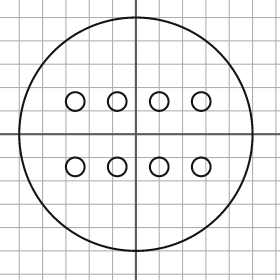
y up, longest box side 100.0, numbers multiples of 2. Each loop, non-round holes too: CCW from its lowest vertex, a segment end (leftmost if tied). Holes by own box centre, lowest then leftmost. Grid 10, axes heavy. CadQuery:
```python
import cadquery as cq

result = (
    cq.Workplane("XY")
    .moveTo(0.0, 0.0)
    .circle(50.0)
    .moveTo(-26.0, -14.0)
    .circle(4.0)
    .moveTo(-8.0, -14.0)
    .circle(4.0)
    .moveTo(10.0, -14.0)
    .circle(4.0)
    .moveTo(28.0, -14.0)
    .circle(4.0)
    .moveTo(-26.0, 14.0)
    .circle(4.0)
    .moveTo(-8.0, 14.0)
    .circle(4.0)
    .moveTo(10.0, 14.0)
    .circle(4.0)
    .moveTo(28.0, 14.0)
    .circle(4.0)
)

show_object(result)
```